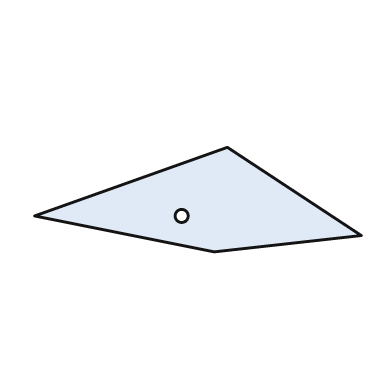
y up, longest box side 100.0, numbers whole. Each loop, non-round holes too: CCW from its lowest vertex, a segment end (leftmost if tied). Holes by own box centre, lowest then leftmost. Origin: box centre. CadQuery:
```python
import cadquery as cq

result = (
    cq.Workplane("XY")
    .moveTo(5.0, -16.0)
    .lineTo(50.0, -11.0)
    .lineTo(9.0, 16.0)
    .lineTo(-50.0, -5.0)
    .close()
    .moveTo(-5.0, -5.0)
    .circle(2.0)
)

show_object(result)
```